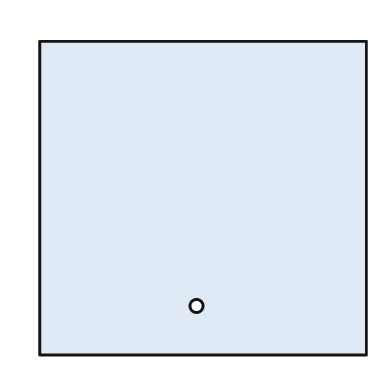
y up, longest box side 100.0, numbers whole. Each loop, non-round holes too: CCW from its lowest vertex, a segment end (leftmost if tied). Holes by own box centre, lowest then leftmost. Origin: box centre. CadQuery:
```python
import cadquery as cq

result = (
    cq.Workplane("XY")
    .moveTo(-50.0, -48.0)
    .lineTo(50.0, -48.0)
    .lineTo(50.0, 48.0)
    .lineTo(-50.0, 48.0)
    .close()
    .moveTo(-2.0, -33.0)
    .circle(2.0)
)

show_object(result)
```